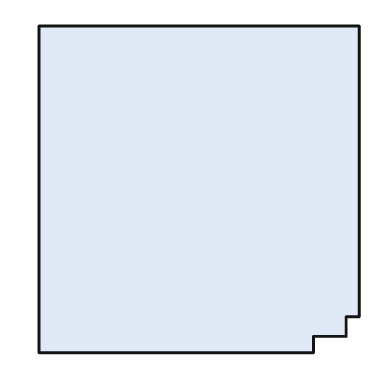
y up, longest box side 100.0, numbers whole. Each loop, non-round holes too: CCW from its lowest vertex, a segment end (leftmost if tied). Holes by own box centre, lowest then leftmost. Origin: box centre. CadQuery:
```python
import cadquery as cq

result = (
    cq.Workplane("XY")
    .moveTo(-49.0, -50.0)
    .lineTo(35.0, -50.0)
    .lineTo(35.0, -45.0)
    .lineTo(45.0, -45.0)
    .lineTo(45.0, -39.0)
    .lineTo(49.0, -39.0)
    .lineTo(49.0, 50.0)
    .lineTo(-49.0, 50.0)
    .close()
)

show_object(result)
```